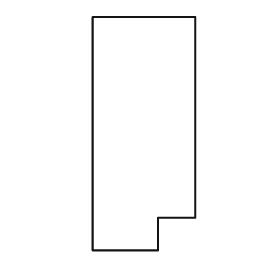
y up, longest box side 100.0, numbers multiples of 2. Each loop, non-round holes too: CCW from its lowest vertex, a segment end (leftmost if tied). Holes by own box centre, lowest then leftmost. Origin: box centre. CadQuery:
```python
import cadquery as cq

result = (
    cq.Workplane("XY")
    .moveTo(-22.0, -50.0)
    .lineTo(6.0, -50.0)
    .lineTo(6.0, -36.0)
    .lineTo(22.0, -36.0)
    .lineTo(22.0, 50.0)
    .lineTo(-22.0, 50.0)
    .close()
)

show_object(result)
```